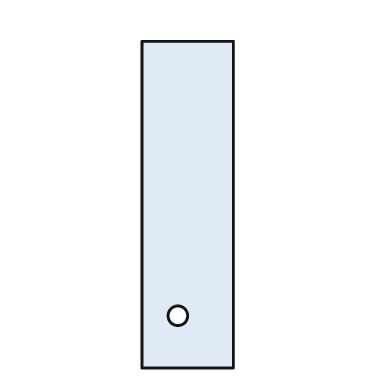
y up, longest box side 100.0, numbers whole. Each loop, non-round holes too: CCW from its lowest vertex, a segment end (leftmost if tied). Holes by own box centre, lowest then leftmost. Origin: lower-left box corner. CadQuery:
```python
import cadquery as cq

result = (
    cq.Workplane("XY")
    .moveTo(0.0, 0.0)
    .lineTo(28.0, 0.0)
    .lineTo(28.0, 100.0)
    .lineTo(0.0, 100.0)
    .close()
    .moveTo(11.0, 16.0)
    .circle(3.0)
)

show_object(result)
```